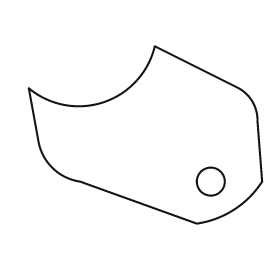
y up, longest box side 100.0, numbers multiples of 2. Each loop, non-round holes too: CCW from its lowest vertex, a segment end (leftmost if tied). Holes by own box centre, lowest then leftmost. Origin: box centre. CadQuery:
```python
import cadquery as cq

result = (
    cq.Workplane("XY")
    .moveTo(22.0, -38.0)
    .threePointArc((38.0, -32.0), (50.0, -20.0))
    .lineTo(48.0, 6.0)
    .threePointArc((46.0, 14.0), (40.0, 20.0))
    .lineTo(4.0, 38.0)
    .threePointArc((-18.0, 14.0), (-50.0, 20.0))
    .lineTo(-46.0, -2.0)
    .threePointArc((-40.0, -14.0), (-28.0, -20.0))
    .close()
    .moveTo(28.0, -20.0)
    .circle(6.0)
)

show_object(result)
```